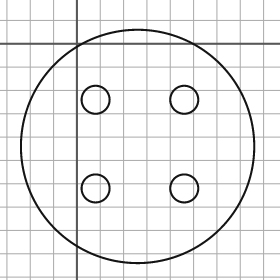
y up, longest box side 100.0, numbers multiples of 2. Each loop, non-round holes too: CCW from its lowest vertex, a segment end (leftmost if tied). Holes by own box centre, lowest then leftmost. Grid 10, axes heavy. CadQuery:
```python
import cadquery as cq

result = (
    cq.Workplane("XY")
    .moveTo(26.0, -44.0)
    .circle(50.0)
    .moveTo(8.0, -62.0)
    .circle(6.0)
    .moveTo(46.0, -62.0)
    .circle(6.0)
    .moveTo(8.0, -24.0)
    .circle(6.0)
    .moveTo(46.0, -24.0)
    .circle(6.0)
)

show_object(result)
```